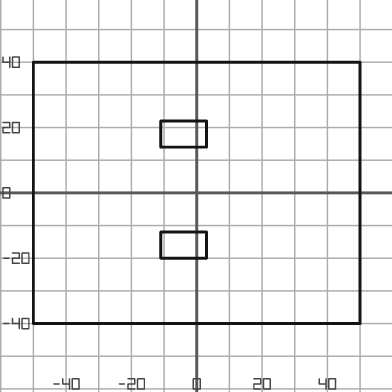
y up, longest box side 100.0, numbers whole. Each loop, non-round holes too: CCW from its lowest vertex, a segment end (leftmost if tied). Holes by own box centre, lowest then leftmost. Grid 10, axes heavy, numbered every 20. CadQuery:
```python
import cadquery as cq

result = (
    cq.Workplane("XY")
    .moveTo(-50.0, -40.0)
    .lineTo(50.0, -40.0)
    .lineTo(50.0, 40.0)
    .lineTo(-50.0, 40.0)
    .close()
    .moveTo(-11.0, -20.0)
    .lineTo(3.0, -20.0)
    .lineTo(3.0, -12.0)
    .lineTo(-11.0, -12.0)
    .close()
    .moveTo(-11.0, 14.0)
    .lineTo(3.0, 14.0)
    .lineTo(3.0, 22.0)
    .lineTo(-11.0, 22.0)
    .close()
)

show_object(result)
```